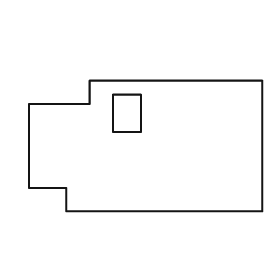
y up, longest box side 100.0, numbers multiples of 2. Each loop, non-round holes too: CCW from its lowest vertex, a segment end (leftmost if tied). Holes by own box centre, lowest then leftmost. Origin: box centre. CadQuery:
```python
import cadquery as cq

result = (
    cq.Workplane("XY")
    .moveTo(-34.0, -28.0)
    .lineTo(50.0, -28.0)
    .lineTo(50.0, 28.0)
    .lineTo(-24.0, 28.0)
    .lineTo(-24.0, 18.0)
    .lineTo(-50.0, 18.0)
    .lineTo(-50.0, -18.0)
    .lineTo(-34.0, -18.0)
    .close()
    .moveTo(-14.0, 6.0)
    .lineTo(-2.0, 6.0)
    .lineTo(-2.0, 22.0)
    .lineTo(-14.0, 22.0)
    .close()
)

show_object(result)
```